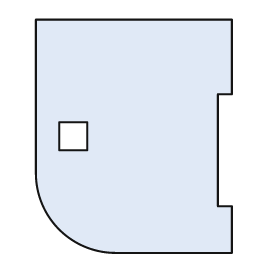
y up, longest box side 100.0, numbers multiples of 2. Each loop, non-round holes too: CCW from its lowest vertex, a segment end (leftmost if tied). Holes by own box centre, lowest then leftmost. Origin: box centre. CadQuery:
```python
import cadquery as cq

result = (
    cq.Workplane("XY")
    .moveTo(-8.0, -50.0)
    .lineTo(42.0, -50.0)
    .lineTo(42.0, -30.0)
    .lineTo(36.0, -30.0)
    .lineTo(36.0, 18.0)
    .lineTo(42.0, 18.0)
    .lineTo(42.0, 50.0)
    .lineTo(-42.0, 50.0)
    .lineTo(-42.0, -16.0)
    .threePointArc((-32.0, -40.0), (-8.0, -50.0))
    .close()
    .moveTo(-32.0, -6.0)
    .lineTo(-20.0, -6.0)
    .lineTo(-20.0, 6.0)
    .lineTo(-32.0, 6.0)
    .close()
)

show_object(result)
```